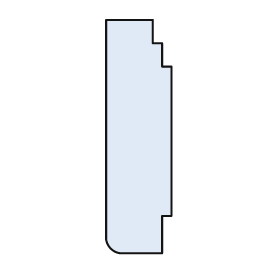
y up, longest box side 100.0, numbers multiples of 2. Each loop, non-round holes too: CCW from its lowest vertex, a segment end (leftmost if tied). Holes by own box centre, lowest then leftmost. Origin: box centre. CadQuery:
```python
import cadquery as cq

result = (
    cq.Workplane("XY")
    .moveTo(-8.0, -50.0)
    .lineTo(10.0, -50.0)
    .lineTo(10.0, -34.0)
    .lineTo(14.0, -34.0)
    .lineTo(14.0, 30.0)
    .lineTo(10.0, 30.0)
    .lineTo(10.0, 40.0)
    .lineTo(6.0, 40.0)
    .lineTo(6.0, 50.0)
    .lineTo(-14.0, 50.0)
    .lineTo(-14.0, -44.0)
    .threePointArc((-12.0, -48.0), (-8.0, -50.0))
    .close()
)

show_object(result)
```